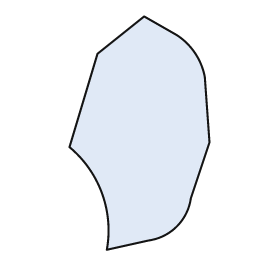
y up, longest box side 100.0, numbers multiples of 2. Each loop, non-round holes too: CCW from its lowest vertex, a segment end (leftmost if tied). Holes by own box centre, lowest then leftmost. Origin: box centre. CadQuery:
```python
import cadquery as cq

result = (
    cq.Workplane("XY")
    .moveTo(-14.0, -50.0)
    .lineTo(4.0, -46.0)
    .threePointArc((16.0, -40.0), (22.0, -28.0))
    .lineTo(30.0, -4.0)
    .lineTo(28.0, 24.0)
    .threePointArc((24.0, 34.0), (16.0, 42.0))
    .lineTo(2.0, 50.0)
    .lineTo(-18.0, 34.0)
    .lineTo(-30.0, -6.0)
    .threePointArc((-16.0, -26.0), (-14.0, -50.0))
    .close()
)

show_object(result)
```